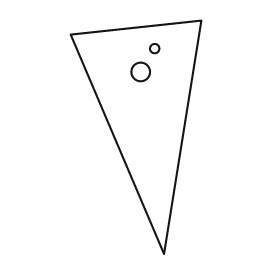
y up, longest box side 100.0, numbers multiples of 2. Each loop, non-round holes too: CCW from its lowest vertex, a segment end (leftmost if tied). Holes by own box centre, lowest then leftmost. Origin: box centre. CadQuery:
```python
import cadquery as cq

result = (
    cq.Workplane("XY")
    .moveTo(12.0, -50.0)
    .lineTo(28.0, 50.0)
    .lineTo(-28.0, 44.0)
    .close()
    .moveTo(2.0, 28.0)
    .circle(4.0)
    .moveTo(8.0, 38.0)
    .circle(2.0)
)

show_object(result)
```